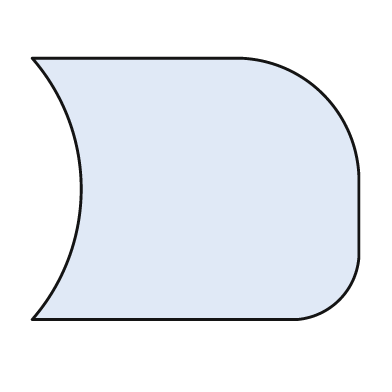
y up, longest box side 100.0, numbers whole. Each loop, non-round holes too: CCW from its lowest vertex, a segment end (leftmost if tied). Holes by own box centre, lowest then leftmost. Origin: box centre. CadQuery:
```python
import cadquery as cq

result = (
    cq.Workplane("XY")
    .moveTo(-50.0, -40.0)
    .lineTo(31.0, -40.0)
    .threePointArc((44.0, -34.0), (50.0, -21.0))
    .lineTo(50.0, 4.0)
    .threePointArc((39.0, 29.0), (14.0, 40.0))
    .lineTo(-50.0, 40.0)
    .threePointArc((-35.0, 0.0), (-50.0, -40.0))
    .close()
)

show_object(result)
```